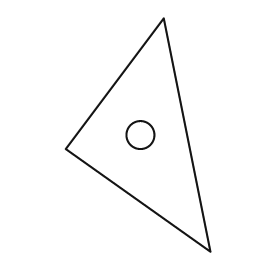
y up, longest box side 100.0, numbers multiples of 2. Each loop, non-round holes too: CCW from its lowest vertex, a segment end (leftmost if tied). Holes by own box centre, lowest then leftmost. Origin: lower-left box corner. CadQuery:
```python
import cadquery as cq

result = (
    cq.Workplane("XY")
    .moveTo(62.0, 0.0)
    .lineTo(42.0, 100.0)
    .lineTo(0.0, 44.0)
    .close()
    .moveTo(32.0, 50.0)
    .circle(6.0)
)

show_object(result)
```